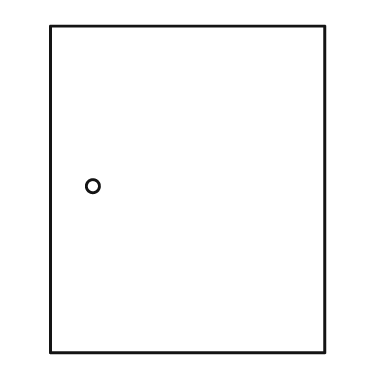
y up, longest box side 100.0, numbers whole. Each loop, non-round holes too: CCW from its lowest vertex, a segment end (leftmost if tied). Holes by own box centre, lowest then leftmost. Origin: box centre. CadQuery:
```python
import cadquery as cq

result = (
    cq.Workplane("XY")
    .moveTo(-42.0, -50.0)
    .lineTo(42.0, -50.0)
    .lineTo(42.0, 50.0)
    .lineTo(-42.0, 50.0)
    .close()
    .moveTo(-29.0, 1.0)
    .circle(2.0)
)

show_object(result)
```